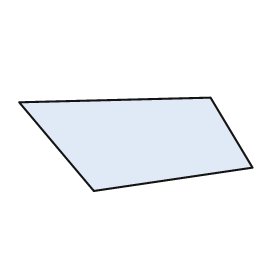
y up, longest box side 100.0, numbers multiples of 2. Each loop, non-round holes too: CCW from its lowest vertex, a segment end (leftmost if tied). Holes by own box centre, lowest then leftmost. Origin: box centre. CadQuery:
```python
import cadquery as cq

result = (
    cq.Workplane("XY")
    .moveTo(-18.0, -20.0)
    .lineTo(50.0, -10.0)
    .lineTo(32.0, 20.0)
    .lineTo(-50.0, 18.0)
    .close()
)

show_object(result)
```